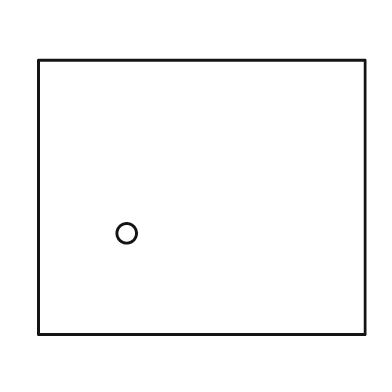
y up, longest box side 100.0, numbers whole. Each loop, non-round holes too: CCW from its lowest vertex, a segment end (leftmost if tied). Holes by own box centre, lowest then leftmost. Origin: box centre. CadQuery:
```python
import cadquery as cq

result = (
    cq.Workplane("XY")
    .moveTo(-50.0, -42.0)
    .lineTo(50.0, -42.0)
    .lineTo(50.0, 42.0)
    .lineTo(-50.0, 42.0)
    .close()
    .moveTo(-23.0, -11.0)
    .circle(3.0)
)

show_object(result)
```